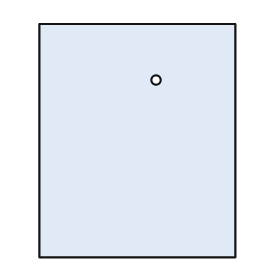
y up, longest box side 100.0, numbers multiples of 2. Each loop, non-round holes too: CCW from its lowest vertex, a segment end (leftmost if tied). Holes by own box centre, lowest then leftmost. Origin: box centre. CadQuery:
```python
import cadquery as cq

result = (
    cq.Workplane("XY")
    .moveTo(-42.0, -50.0)
    .lineTo(42.0, -50.0)
    .lineTo(42.0, 50.0)
    .lineTo(-42.0, 50.0)
    .close()
    .moveTo(8.0, 26.0)
    .circle(2.0)
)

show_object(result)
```